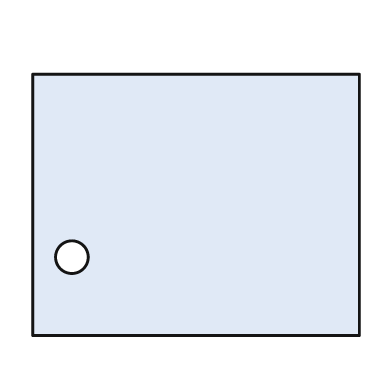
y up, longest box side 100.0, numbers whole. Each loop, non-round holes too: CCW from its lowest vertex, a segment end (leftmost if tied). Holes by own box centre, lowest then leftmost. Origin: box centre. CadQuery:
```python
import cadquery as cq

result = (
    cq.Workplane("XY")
    .moveTo(-50.0, -40.0)
    .lineTo(50.0, -40.0)
    .lineTo(50.0, 40.0)
    .lineTo(-50.0, 40.0)
    .close()
    .moveTo(-38.0, -16.0)
    .circle(5.0)
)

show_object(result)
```